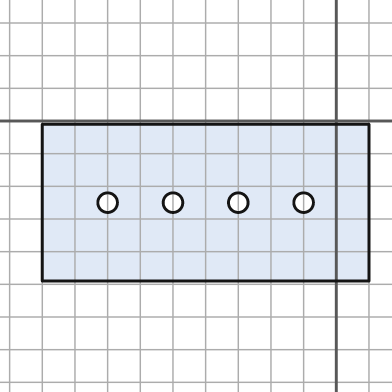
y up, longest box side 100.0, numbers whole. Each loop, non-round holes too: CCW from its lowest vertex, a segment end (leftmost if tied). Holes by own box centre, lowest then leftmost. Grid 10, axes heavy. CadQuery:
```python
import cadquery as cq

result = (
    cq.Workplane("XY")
    .moveTo(-90.0, -49.0)
    .lineTo(10.0, -49.0)
    .lineTo(10.0, -1.0)
    .lineTo(-90.0, -1.0)
    .close()
    .moveTo(-70.0, -25.0)
    .circle(3.0)
    .moveTo(-50.0, -25.0)
    .circle(3.0)
    .moveTo(-30.0, -25.0)
    .circle(3.0)
    .moveTo(-10.0, -25.0)
    .circle(3.0)
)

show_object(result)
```